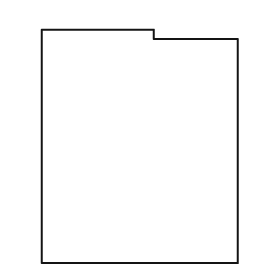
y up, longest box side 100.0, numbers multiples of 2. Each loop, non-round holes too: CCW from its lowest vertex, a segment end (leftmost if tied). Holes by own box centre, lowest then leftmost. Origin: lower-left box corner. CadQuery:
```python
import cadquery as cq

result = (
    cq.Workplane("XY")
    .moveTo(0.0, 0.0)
    .lineTo(84.0, 0.0)
    .lineTo(84.0, 96.0)
    .lineTo(48.0, 96.0)
    .lineTo(48.0, 100.0)
    .lineTo(0.0, 100.0)
    .close()
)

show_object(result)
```